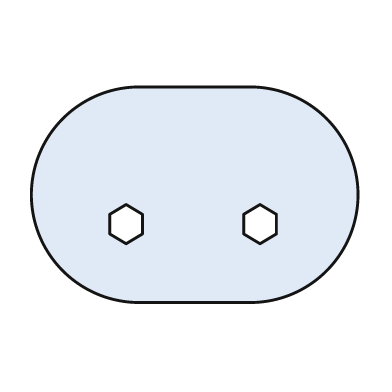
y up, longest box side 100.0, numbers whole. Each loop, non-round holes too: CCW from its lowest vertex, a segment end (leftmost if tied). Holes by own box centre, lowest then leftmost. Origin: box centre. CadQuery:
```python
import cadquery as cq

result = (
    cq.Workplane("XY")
    .moveTo(-17.0, -33.0)
    .lineTo(17.0, -33.0)
    .threePointArc((50.0, 0.0), (17.0, 33.0))
    .lineTo(-17.0, 33.0)
    .threePointArc((-50.0, 0.0), (-17.0, -33.0))
    .close()
    .moveTo(-21.0, -15.0)
    .lineTo(-16.0, -12.0)
    .lineTo(-16.0, -6.0)
    .lineTo(-21.0, -3.0)
    .lineTo(-26.0, -6.0)
    .lineTo(-26.0, -12.0)
    .close()
    .moveTo(20.0, -15.0)
    .lineTo(25.0, -12.0)
    .lineTo(25.0, -6.0)
    .lineTo(20.0, -3.0)
    .lineTo(15.0, -6.0)
    .lineTo(15.0, -12.0)
    .close()
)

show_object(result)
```